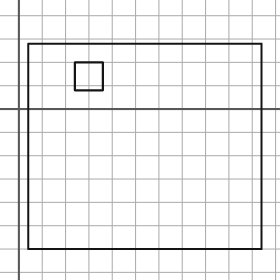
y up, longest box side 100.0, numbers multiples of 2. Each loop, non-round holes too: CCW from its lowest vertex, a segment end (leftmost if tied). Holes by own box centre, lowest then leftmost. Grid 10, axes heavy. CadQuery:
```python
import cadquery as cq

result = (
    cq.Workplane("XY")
    .moveTo(4.0, -60.0)
    .lineTo(104.0, -60.0)
    .lineTo(104.0, 28.0)
    .lineTo(4.0, 28.0)
    .close()
    .moveTo(24.0, 8.0)
    .lineTo(36.0, 8.0)
    .lineTo(36.0, 20.0)
    .lineTo(24.0, 20.0)
    .close()
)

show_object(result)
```